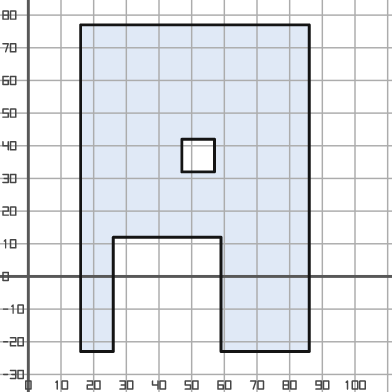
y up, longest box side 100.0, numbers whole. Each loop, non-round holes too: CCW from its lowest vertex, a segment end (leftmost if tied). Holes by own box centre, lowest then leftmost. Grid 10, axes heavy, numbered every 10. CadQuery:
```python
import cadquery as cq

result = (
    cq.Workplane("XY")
    .moveTo(16.0, -23.0)
    .lineTo(26.0, -23.0)
    .lineTo(26.0, 12.0)
    .lineTo(59.0, 12.0)
    .lineTo(59.0, -23.0)
    .lineTo(86.0, -23.0)
    .lineTo(86.0, 77.0)
    .lineTo(16.0, 77.0)
    .close()
    .moveTo(47.0, 32.0)
    .lineTo(57.0, 32.0)
    .lineTo(57.0, 42.0)
    .lineTo(47.0, 42.0)
    .close()
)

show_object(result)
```